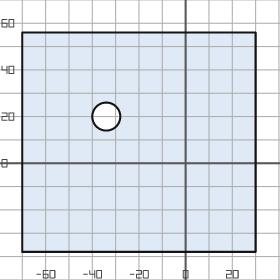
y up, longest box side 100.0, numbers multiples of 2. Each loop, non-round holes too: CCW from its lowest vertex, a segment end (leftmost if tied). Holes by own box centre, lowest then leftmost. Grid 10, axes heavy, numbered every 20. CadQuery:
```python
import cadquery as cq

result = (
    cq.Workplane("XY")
    .moveTo(-70.0, -38.0)
    .lineTo(30.0, -38.0)
    .lineTo(30.0, 56.0)
    .lineTo(-70.0, 56.0)
    .close()
    .moveTo(-34.0, 20.0)
    .circle(6.0)
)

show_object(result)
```